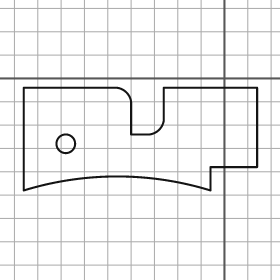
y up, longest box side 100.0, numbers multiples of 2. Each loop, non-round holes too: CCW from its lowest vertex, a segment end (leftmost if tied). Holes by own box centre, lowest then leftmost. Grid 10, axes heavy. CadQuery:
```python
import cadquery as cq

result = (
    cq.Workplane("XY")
    .moveTo(-86.0, -48.0)
    .threePointArc((-46.0, -42.0), (-6.0, -48.0))
    .lineTo(-6.0, -38.0)
    .lineTo(14.0, -38.0)
    .lineTo(14.0, -4.0)
    .lineTo(-26.0, -4.0)
    .lineTo(-26.0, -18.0)
    .threePointArc((-28.0, -22.0), (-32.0, -24.0))
    .lineTo(-40.0, -24.0)
    .lineTo(-40.0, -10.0)
    .threePointArc((-42.0, -6.0), (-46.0, -4.0))
    .lineTo(-86.0, -4.0)
    .close()
    .moveTo(-68.0, -28.0)
    .circle(4.0)
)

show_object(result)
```